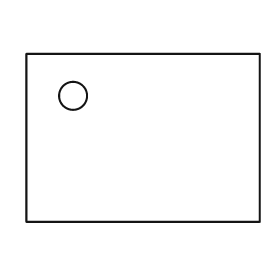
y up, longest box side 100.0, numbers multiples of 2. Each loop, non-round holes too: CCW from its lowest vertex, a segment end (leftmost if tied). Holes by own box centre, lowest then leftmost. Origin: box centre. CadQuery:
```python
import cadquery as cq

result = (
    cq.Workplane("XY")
    .moveTo(-50.0, -36.0)
    .lineTo(50.0, -36.0)
    .lineTo(50.0, 36.0)
    .lineTo(-50.0, 36.0)
    .close()
    .moveTo(-30.0, 18.0)
    .circle(6.0)
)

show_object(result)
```